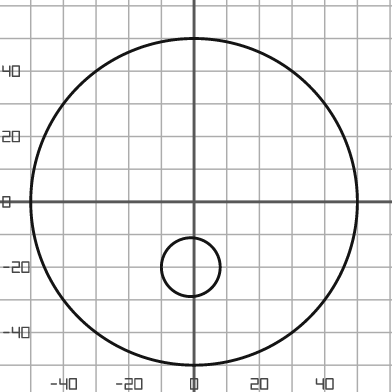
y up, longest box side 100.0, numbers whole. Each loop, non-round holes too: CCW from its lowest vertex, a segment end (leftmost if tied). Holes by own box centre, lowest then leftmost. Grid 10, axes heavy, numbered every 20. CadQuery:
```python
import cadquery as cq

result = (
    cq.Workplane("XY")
    .moveTo(0.0, 0.0)
    .circle(50.0)
    .moveTo(-1.0, -20.0)
    .circle(9.0)
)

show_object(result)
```